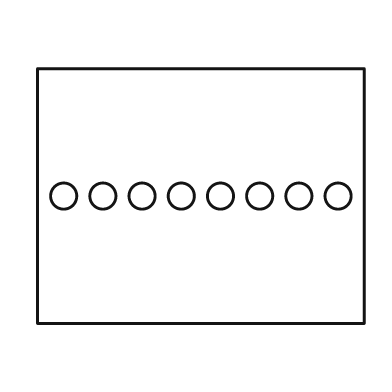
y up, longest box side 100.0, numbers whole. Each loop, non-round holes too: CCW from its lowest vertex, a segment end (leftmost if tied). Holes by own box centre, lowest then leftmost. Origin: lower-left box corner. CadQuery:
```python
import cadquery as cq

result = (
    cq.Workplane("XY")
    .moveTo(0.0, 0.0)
    .lineTo(100.0, 0.0)
    .lineTo(100.0, 78.0)
    .lineTo(0.0, 78.0)
    .close()
    .moveTo(8.0, 39.0)
    .circle(4.0)
    .moveTo(20.0, 39.0)
    .circle(4.0)
    .moveTo(32.0, 39.0)
    .circle(4.0)
    .moveTo(44.0, 39.0)
    .circle(4.0)
    .moveTo(56.0, 39.0)
    .circle(4.0)
    .moveTo(68.0, 39.0)
    .circle(4.0)
    .moveTo(80.0, 39.0)
    .circle(4.0)
    .moveTo(92.0, 39.0)
    .circle(4.0)
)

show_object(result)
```